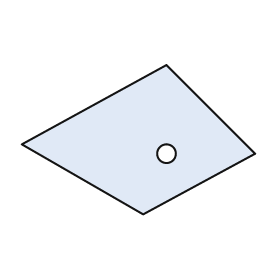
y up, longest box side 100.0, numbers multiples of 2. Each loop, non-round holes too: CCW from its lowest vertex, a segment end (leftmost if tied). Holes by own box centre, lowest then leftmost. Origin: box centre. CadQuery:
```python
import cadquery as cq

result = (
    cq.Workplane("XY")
    .moveTo(2.0, -32.0)
    .lineTo(50.0, -6.0)
    .lineTo(12.0, 32.0)
    .lineTo(-50.0, -2.0)
    .close()
    .moveTo(12.0, -6.0)
    .circle(4.0)
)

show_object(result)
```